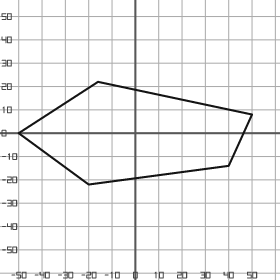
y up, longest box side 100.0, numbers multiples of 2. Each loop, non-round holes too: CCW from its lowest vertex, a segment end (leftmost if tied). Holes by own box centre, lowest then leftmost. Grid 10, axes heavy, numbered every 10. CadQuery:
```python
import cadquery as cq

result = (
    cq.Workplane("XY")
    .moveTo(-20.0, -22.0)
    .lineTo(40.0, -14.0)
    .lineTo(50.0, 8.0)
    .lineTo(-16.0, 22.0)
    .lineTo(-50.0, 0.0)
    .close()
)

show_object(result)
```